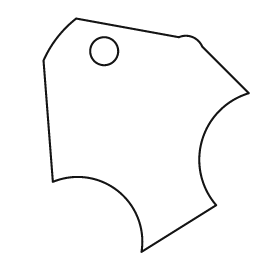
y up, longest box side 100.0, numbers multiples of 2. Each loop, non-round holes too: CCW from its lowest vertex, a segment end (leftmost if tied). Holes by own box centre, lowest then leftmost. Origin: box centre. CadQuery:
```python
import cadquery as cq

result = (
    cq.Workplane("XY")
    .moveTo(-2.0, -50.0)
    .lineTo(30.0, -30.0)
    .threePointArc((24.0, -2.0), (44.0, 18.0))
    .lineTo(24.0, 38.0)
    .threePointArc((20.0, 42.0), (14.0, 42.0))
    .lineTo(-30.0, 50.0)
    .threePointArc((-38.0, 42.0), (-44.0, 32.0))
    .lineTo(-40.0, -20.0)
    .threePointArc((-12.0, -24.0), (-2.0, -50.0))
    .close()
    .moveTo(-18.0, 36.0)
    .circle(6.0)
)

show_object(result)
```